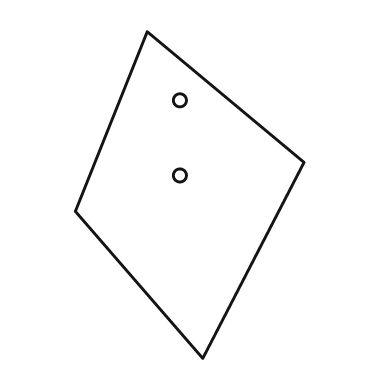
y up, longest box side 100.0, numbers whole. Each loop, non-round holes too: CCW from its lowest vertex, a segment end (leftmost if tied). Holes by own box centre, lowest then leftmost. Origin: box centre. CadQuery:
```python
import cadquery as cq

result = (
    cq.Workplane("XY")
    .moveTo(4.0, -50.0)
    .lineTo(35.0, 10.0)
    .lineTo(-13.0, 50.0)
    .lineTo(-35.0, -5.0)
    .close()
    .moveTo(-3.0, 6.0)
    .circle(2.0)
    .moveTo(-3.0, 29.0)
    .circle(2.0)
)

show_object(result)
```